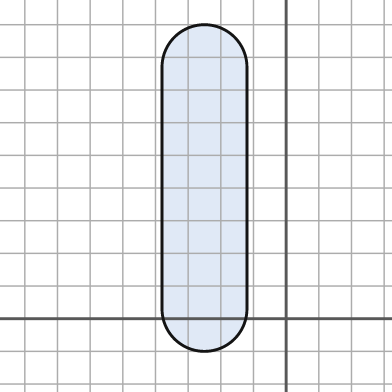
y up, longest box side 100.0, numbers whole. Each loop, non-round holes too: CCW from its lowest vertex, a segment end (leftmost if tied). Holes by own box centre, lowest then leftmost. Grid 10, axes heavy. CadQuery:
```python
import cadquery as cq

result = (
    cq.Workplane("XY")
    .moveTo(-38.0, 3.0)
    .threePointArc((-25.0, -10.0), (-12.0, 3.0))
    .lineTo(-12.0, 77.0)
    .threePointArc((-25.0, 90.0), (-38.0, 77.0))
    .close()
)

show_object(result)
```